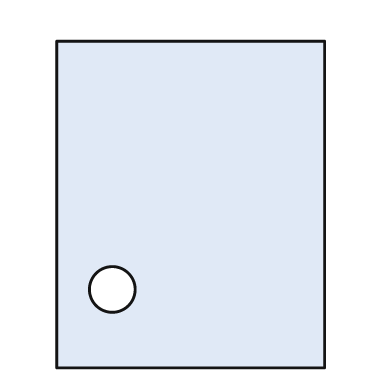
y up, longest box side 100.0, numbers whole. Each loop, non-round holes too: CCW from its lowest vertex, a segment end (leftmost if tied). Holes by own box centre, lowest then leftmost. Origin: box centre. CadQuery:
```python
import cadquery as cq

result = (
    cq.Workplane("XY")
    .moveTo(-41.0, -50.0)
    .lineTo(41.0, -50.0)
    .lineTo(41.0, 50.0)
    .lineTo(-41.0, 50.0)
    .close()
    .moveTo(-24.0, -26.0)
    .circle(7.0)
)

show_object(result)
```